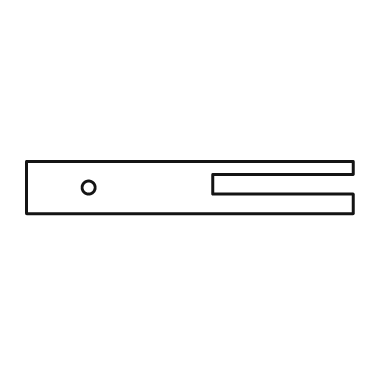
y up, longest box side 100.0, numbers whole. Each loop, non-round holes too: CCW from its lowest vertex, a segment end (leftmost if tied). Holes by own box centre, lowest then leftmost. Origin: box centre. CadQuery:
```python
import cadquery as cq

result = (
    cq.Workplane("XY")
    .moveTo(-50.0, -8.0)
    .lineTo(50.0, -8.0)
    .lineTo(50.0, -2.0)
    .lineTo(7.0, -2.0)
    .lineTo(7.0, 4.0)
    .lineTo(50.0, 4.0)
    .lineTo(50.0, 8.0)
    .lineTo(-50.0, 8.0)
    .close()
    .moveTo(-31.0, 0.0)
    .circle(2.0)
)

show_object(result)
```